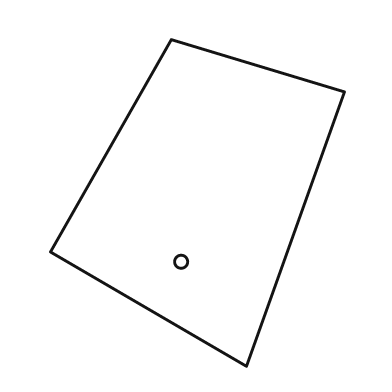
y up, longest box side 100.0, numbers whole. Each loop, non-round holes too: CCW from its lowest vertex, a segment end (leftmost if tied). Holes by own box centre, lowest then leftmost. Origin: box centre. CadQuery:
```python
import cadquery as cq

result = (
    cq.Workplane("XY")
    .moveTo(15.0, -50.0)
    .lineTo(45.0, 34.0)
    .lineTo(-8.0, 50.0)
    .lineTo(-45.0, -15.0)
    .close()
    .moveTo(-5.0, -18.0)
    .circle(2.0)
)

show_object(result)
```